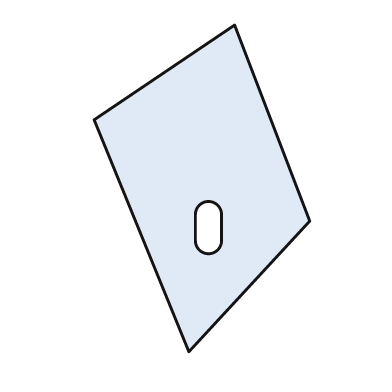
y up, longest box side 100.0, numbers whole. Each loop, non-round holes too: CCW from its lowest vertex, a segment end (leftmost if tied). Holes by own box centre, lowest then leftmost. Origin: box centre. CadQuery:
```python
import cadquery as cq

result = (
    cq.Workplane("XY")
    .moveTo(-4.0, -50.0)
    .lineTo(33.0, -10.0)
    .lineTo(10.0, 50.0)
    .lineTo(-33.0, 21.0)
    .close()
    .moveTo(-2.0, -16.0)
    .threePointArc((2.0, -20.0), (6.0, -16.0))
    .lineTo(6.0, -8.0)
    .threePointArc((2.0, -4.0), (-2.0, -8.0))
    .close()
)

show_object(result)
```